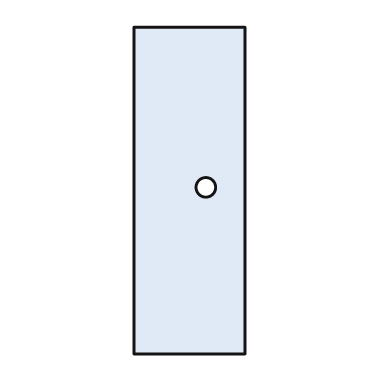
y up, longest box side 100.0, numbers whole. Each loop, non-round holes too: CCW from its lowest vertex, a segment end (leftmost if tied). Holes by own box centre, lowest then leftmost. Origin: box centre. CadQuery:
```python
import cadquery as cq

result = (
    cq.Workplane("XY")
    .moveTo(-17.0, -50.0)
    .lineTo(17.0, -50.0)
    .lineTo(17.0, 50.0)
    .lineTo(-17.0, 50.0)
    .close()
    .moveTo(5.0, 1.0)
    .circle(3.0)
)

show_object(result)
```